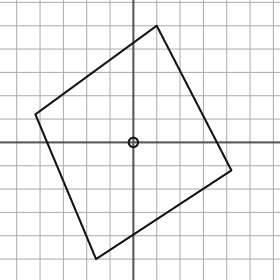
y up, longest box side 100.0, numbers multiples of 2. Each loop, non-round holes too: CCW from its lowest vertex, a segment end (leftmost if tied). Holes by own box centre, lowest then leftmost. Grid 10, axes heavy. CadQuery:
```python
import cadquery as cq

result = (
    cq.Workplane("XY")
    .moveTo(-16.0, -50.0)
    .lineTo(42.0, -12.0)
    .lineTo(10.0, 50.0)
    .lineTo(-42.0, 12.0)
    .close()
    .moveTo(0.0, 0.0)
    .circle(2.0)
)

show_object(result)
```